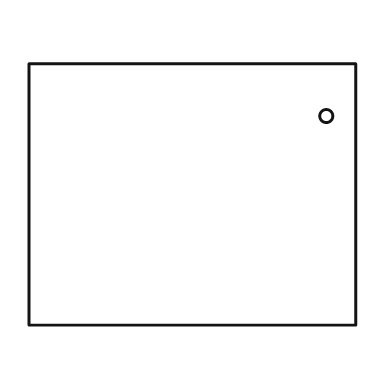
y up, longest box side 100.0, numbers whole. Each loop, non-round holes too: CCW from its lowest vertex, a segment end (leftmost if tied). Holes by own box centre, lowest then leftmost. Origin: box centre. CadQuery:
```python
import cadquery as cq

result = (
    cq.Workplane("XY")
    .moveTo(-50.0, -40.0)
    .lineTo(50.0, -40.0)
    .lineTo(50.0, 40.0)
    .lineTo(-50.0, 40.0)
    .close()
    .moveTo(41.0, 24.0)
    .circle(2.0)
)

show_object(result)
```